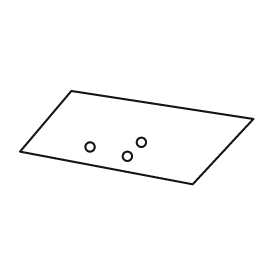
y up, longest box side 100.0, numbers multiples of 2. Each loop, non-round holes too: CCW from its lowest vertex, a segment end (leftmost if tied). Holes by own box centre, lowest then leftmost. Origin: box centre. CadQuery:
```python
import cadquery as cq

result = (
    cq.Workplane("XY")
    .moveTo(24.0, -20.0)
    .lineTo(50.0, 8.0)
    .lineTo(-28.0, 20.0)
    .lineTo(-50.0, -6.0)
    .close()
    .moveTo(-4.0, -8.0)
    .circle(2.0)
    .moveTo(-20.0, -4.0)
    .circle(2.0)
    .moveTo(2.0, -2.0)
    .circle(2.0)
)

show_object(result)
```